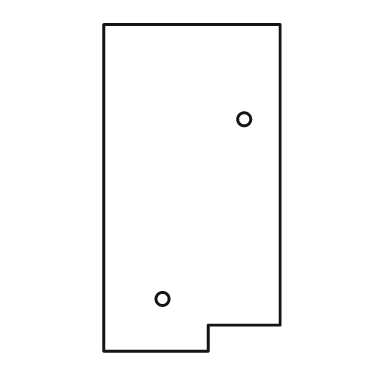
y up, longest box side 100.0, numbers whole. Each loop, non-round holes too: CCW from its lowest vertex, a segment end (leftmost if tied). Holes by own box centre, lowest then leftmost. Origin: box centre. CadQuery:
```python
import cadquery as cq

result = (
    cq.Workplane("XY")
    .moveTo(-27.0, -50.0)
    .lineTo(5.0, -50.0)
    .lineTo(5.0, -42.0)
    .lineTo(27.0, -42.0)
    .lineTo(27.0, 50.0)
    .lineTo(-27.0, 50.0)
    .close()
    .moveTo(-9.0, -34.0)
    .circle(2.0)
    .moveTo(16.0, 21.0)
    .circle(2.0)
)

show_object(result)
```